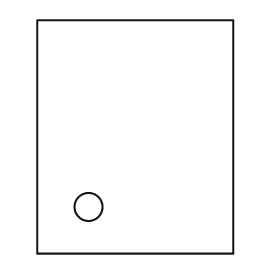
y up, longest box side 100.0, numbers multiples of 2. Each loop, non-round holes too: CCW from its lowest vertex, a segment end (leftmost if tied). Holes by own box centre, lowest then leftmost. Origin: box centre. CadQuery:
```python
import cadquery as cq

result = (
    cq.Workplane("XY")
    .moveTo(-42.0, -50.0)
    .lineTo(42.0, -50.0)
    .lineTo(42.0, 50.0)
    .lineTo(-42.0, 50.0)
    .close()
    .moveTo(-20.0, -30.0)
    .circle(6.0)
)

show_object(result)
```